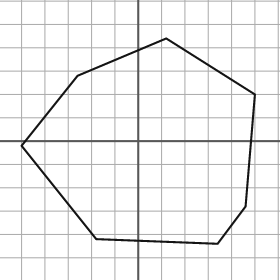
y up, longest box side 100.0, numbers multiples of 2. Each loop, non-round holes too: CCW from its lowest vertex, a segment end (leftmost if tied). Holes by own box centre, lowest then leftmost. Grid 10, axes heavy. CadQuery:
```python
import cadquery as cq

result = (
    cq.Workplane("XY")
    .moveTo(34.0, -44.0)
    .lineTo(46.0, -28.0)
    .lineTo(50.0, 20.0)
    .lineTo(12.0, 44.0)
    .lineTo(-26.0, 28.0)
    .lineTo(-50.0, -2.0)
    .lineTo(-18.0, -42.0)
    .close()
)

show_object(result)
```